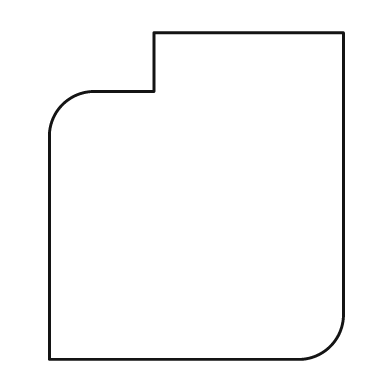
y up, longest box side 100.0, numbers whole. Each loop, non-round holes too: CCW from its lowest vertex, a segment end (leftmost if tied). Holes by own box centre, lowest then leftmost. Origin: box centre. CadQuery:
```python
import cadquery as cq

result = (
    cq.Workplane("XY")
    .moveTo(-45.0, -50.0)
    .lineTo(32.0, -50.0)
    .threePointArc((41.0, -46.0), (45.0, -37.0))
    .lineTo(45.0, 50.0)
    .lineTo(-13.0, 50.0)
    .lineTo(-13.0, 32.0)
    .lineTo(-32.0, 32.0)
    .threePointArc((-41.0, 28.0), (-45.0, 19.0))
    .close()
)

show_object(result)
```